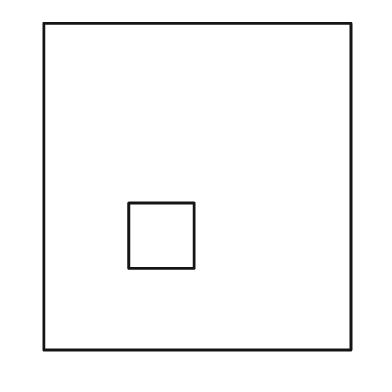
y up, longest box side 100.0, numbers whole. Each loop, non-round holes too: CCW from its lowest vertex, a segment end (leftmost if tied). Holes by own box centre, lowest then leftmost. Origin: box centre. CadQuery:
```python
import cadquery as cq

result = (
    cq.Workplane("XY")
    .moveTo(-47.0, -50.0)
    .lineTo(47.0, -50.0)
    .lineTo(47.0, 50.0)
    .lineTo(-47.0, 50.0)
    .close()
    .moveTo(-21.0, -25.0)
    .lineTo(-1.0, -25.0)
    .lineTo(-1.0, -5.0)
    .lineTo(-21.0, -5.0)
    .close()
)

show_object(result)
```